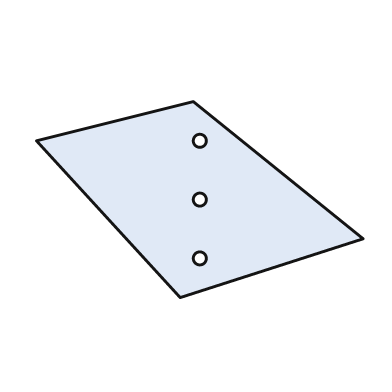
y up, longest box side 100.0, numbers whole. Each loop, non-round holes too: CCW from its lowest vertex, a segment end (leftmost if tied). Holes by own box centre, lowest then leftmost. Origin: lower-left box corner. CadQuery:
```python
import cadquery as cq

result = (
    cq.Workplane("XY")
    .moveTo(44.0, 0.0)
    .lineTo(100.0, 18.0)
    .lineTo(48.0, 60.0)
    .lineTo(0.0, 48.0)
    .close()
    .moveTo(50.0, 12.0)
    .circle(2.0)
    .moveTo(50.0, 30.0)
    .circle(2.0)
    .moveTo(50.0, 48.0)
    .circle(2.0)
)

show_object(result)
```